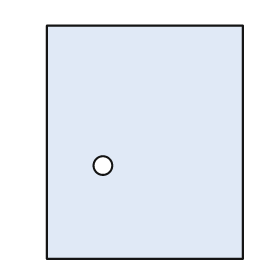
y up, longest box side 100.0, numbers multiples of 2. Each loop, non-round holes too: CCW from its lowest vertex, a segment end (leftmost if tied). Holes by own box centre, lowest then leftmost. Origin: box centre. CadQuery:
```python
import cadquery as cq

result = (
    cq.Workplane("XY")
    .moveTo(-42.0, -50.0)
    .lineTo(42.0, -50.0)
    .lineTo(42.0, 50.0)
    .lineTo(-42.0, 50.0)
    .close()
    .moveTo(-18.0, -10.0)
    .circle(4.0)
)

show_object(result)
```